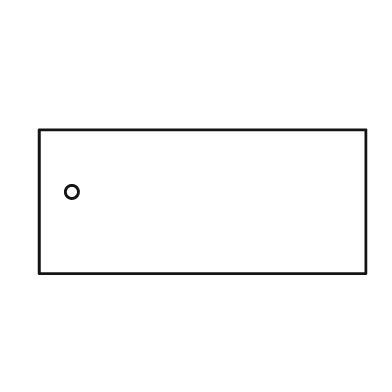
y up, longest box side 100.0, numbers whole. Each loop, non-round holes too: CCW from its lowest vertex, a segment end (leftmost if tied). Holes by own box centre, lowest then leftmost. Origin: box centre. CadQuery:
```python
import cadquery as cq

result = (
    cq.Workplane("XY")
    .moveTo(-50.0, -22.0)
    .lineTo(50.0, -22.0)
    .lineTo(50.0, 22.0)
    .lineTo(-50.0, 22.0)
    .close()
    .moveTo(-40.0, 3.0)
    .circle(2.0)
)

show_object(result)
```